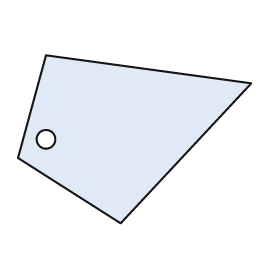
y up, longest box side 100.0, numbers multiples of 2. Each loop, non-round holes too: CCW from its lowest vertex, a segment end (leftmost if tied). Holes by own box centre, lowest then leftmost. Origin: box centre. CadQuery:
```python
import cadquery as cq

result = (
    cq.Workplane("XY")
    .moveTo(-6.0, -36.0)
    .lineTo(50.0, 24.0)
    .lineTo(-38.0, 36.0)
    .lineTo(-50.0, -8.0)
    .close()
    .moveTo(-38.0, 0.0)
    .circle(4.0)
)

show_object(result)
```